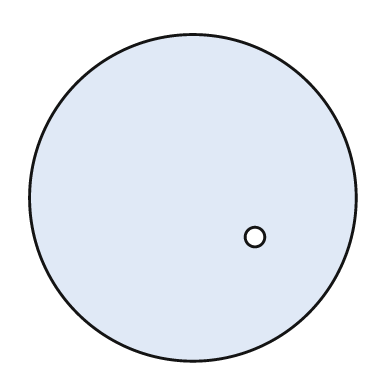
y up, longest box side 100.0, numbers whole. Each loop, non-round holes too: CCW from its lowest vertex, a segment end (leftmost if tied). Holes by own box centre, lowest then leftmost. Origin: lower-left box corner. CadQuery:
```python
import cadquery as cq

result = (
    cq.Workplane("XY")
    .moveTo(50.0, 50.0)
    .circle(50.0)
    .moveTo(69.0, 38.0)
    .circle(3.0)
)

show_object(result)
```